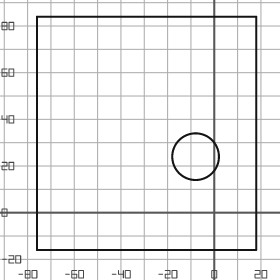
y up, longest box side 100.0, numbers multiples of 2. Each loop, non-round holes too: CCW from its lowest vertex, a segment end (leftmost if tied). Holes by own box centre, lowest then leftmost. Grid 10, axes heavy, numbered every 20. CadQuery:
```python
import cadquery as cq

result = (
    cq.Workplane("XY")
    .moveTo(-76.0, -16.0)
    .lineTo(18.0, -16.0)
    .lineTo(18.0, 84.0)
    .lineTo(-76.0, 84.0)
    .close()
    .moveTo(-8.0, 24.0)
    .circle(10.0)
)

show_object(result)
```